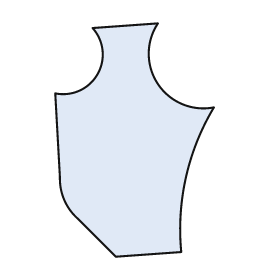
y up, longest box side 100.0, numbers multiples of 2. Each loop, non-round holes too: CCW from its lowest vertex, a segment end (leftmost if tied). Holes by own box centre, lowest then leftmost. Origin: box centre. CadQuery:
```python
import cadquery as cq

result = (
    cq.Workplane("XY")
    .moveTo(-8.0, -50.0)
    .lineTo(20.0, -48.0)
    .threePointArc((22.0, -16.0), (34.0, 14.0))
    .threePointArc((10.0, 24.0), (10.0, 50.0))
    .lineTo(-18.0, 48.0)
    .threePointArc((-16.0, 28.0), (-34.0, 20.0))
    .lineTo(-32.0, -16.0)
    .threePointArc((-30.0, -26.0), (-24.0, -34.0))
    .close()
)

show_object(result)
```